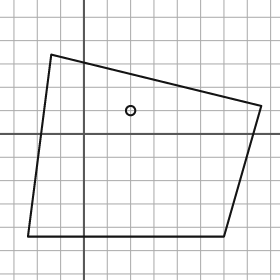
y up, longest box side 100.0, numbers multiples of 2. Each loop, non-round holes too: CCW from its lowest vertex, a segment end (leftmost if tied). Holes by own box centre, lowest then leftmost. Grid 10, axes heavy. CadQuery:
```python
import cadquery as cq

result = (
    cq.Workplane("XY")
    .moveTo(-24.0, -44.0)
    .lineTo(60.0, -44.0)
    .lineTo(76.0, 12.0)
    .lineTo(-14.0, 34.0)
    .close()
    .moveTo(20.0, 10.0)
    .circle(2.0)
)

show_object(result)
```